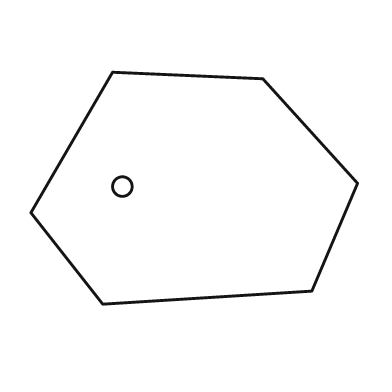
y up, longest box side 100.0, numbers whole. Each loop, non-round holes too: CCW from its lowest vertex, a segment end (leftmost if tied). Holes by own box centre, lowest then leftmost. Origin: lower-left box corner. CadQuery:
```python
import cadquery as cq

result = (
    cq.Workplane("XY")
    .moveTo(22.0, 0.0)
    .lineTo(86.0, 4.0)
    .lineTo(100.0, 37.0)
    .lineTo(71.0, 69.0)
    .lineTo(25.0, 71.0)
    .lineTo(0.0, 28.0)
    .close()
    .moveTo(28.0, 36.0)
    .circle(3.0)
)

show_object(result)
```